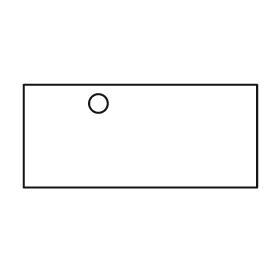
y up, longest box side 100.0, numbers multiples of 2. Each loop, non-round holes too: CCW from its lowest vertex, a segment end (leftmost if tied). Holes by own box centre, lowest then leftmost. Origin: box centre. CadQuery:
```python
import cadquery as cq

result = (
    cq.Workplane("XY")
    .moveTo(-50.0, -22.0)
    .lineTo(50.0, -22.0)
    .lineTo(50.0, 22.0)
    .lineTo(-50.0, 22.0)
    .close()
    .moveTo(-18.0, 14.0)
    .circle(4.0)
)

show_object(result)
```